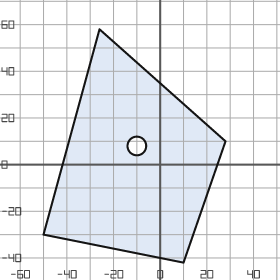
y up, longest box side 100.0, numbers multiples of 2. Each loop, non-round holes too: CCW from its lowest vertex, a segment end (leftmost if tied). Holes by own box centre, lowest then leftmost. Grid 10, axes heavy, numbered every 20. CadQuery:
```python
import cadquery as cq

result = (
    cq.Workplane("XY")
    .moveTo(10.0, -42.0)
    .lineTo(28.0, 10.0)
    .lineTo(-26.0, 58.0)
    .lineTo(-50.0, -30.0)
    .close()
    .moveTo(-10.0, 8.0)
    .circle(4.0)
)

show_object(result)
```